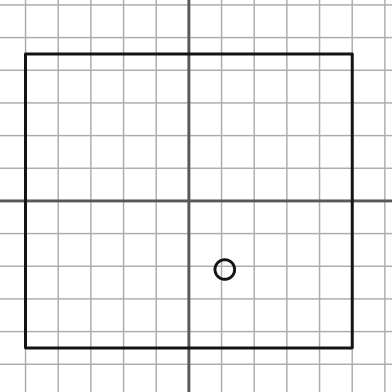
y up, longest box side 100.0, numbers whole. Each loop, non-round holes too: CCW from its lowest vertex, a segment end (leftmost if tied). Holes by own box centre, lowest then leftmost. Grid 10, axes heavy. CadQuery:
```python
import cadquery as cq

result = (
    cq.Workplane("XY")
    .moveTo(-50.0, -45.0)
    .lineTo(50.0, -45.0)
    .lineTo(50.0, 45.0)
    .lineTo(-50.0, 45.0)
    .close()
    .moveTo(11.0, -21.0)
    .circle(3.0)
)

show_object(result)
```